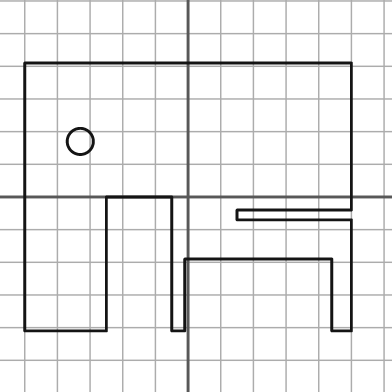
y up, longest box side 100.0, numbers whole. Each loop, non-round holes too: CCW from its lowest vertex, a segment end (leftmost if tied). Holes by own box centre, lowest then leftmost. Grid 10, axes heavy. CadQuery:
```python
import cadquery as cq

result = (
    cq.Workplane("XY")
    .moveTo(-50.0, -41.0)
    .lineTo(-25.0, -41.0)
    .lineTo(-25.0, 0.0)
    .lineTo(-5.0, 0.0)
    .lineTo(-5.0, -41.0)
    .lineTo(-1.0, -41.0)
    .lineTo(-1.0, -19.0)
    .lineTo(44.0, -19.0)
    .lineTo(44.0, -41.0)
    .lineTo(50.0, -41.0)
    .lineTo(50.0, -7.0)
    .lineTo(15.0, -7.0)
    .lineTo(15.0, -4.0)
    .lineTo(50.0, -4.0)
    .lineTo(50.0, 41.0)
    .lineTo(-50.0, 41.0)
    .close()
    .moveTo(-33.0, 17.0)
    .circle(4.0)
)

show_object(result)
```